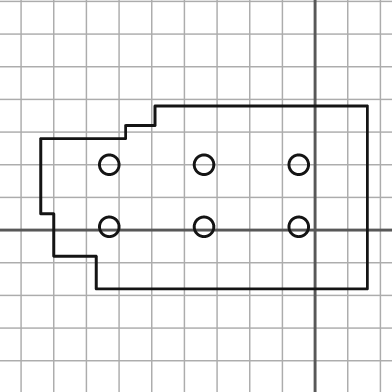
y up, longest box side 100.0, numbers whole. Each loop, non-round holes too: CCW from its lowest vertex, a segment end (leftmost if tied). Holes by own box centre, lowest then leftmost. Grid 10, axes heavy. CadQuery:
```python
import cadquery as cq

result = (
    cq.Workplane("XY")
    .moveTo(-67.0, -18.0)
    .lineTo(16.0, -18.0)
    .lineTo(16.0, 38.0)
    .lineTo(-49.0, 38.0)
    .lineTo(-49.0, 32.0)
    .lineTo(-58.0, 32.0)
    .lineTo(-58.0, 28.0)
    .lineTo(-84.0, 28.0)
    .lineTo(-84.0, 5.0)
    .lineTo(-80.0, 5.0)
    .lineTo(-80.0, -8.0)
    .lineTo(-67.0, -8.0)
    .close()
    .moveTo(-63.0, 1.0)
    .circle(3.0)
    .moveTo(-34.0, 1.0)
    .circle(3.0)
    .moveTo(-5.0, 1.0)
    .circle(3.0)
    .moveTo(-63.0, 20.0)
    .circle(3.0)
    .moveTo(-34.0, 20.0)
    .circle(3.0)
    .moveTo(-5.0, 20.0)
    .circle(3.0)
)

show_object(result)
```